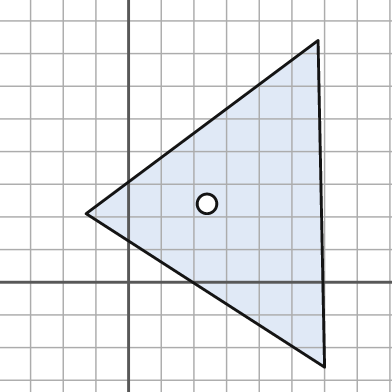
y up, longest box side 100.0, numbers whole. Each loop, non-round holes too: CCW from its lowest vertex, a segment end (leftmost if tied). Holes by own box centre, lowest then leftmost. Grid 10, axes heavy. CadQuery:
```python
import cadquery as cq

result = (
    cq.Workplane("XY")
    .moveTo(60.0, -26.0)
    .lineTo(58.0, 74.0)
    .lineTo(-13.0, 21.0)
    .close()
    .moveTo(24.0, 24.0)
    .circle(3.0)
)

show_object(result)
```